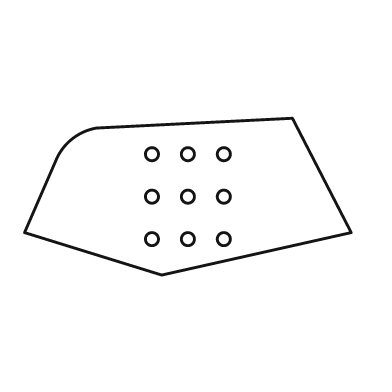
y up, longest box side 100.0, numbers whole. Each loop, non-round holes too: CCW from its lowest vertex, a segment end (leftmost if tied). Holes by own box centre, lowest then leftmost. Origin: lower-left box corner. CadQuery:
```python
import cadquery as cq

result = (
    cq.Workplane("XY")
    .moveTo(42.0, 0.0)
    .lineTo(100.0, 13.0)
    .lineTo(82.0, 48.0)
    .lineTo(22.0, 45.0)
    .threePointArc((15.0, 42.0), (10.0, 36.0))
    .lineTo(0.0, 13.0)
    .close()
    .moveTo(39.0, 11.0)
    .circle(2.0)
    .moveTo(50.0, 11.0)
    .circle(2.0)
    .moveTo(61.0, 11.0)
    .circle(2.0)
    .moveTo(39.0, 24.0)
    .circle(2.0)
    .moveTo(50.0, 24.0)
    .circle(2.0)
    .moveTo(61.0, 24.0)
    .circle(2.0)
    .moveTo(39.0, 37.0)
    .circle(2.0)
    .moveTo(50.0, 37.0)
    .circle(2.0)
    .moveTo(61.0, 37.0)
    .circle(2.0)
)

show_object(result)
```